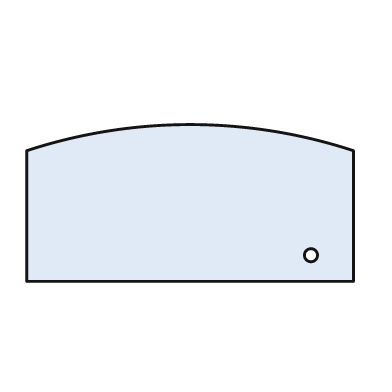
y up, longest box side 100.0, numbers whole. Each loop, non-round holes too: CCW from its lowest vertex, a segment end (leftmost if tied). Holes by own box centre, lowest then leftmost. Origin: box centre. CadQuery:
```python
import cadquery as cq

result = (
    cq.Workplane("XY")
    .moveTo(-50.0, -24.0)
    .lineTo(50.0, -24.0)
    .lineTo(50.0, 16.0)
    .threePointArc((0.0, 24.0), (-50.0, 16.0))
    .close()
    .moveTo(37.0, -16.0)
    .circle(2.0)
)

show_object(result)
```